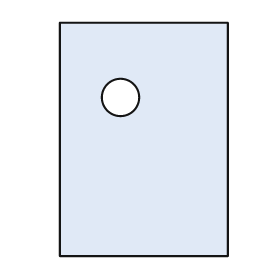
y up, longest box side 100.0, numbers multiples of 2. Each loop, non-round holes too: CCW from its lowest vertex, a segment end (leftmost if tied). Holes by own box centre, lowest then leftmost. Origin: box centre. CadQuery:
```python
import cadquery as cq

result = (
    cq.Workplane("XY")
    .moveTo(-36.0, -50.0)
    .lineTo(36.0, -50.0)
    .lineTo(36.0, 50.0)
    .lineTo(-36.0, 50.0)
    .close()
    .moveTo(-10.0, 18.0)
    .circle(8.0)
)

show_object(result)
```